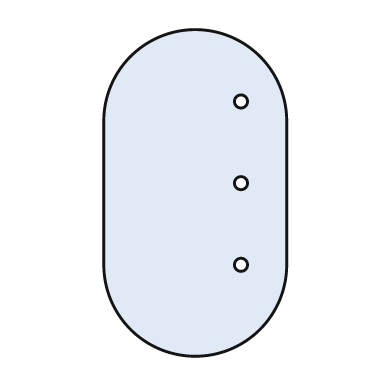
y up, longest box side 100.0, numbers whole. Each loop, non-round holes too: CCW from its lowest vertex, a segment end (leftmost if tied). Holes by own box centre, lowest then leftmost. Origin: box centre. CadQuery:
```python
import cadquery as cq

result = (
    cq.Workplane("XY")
    .moveTo(-28.0, -22.0)
    .threePointArc((0.0, -50.0), (28.0, -22.0))
    .lineTo(28.0, 22.0)
    .threePointArc((0.0, 50.0), (-28.0, 22.0))
    .close()
    .moveTo(14.0, -22.0)
    .circle(2.0)
    .moveTo(14.0, 3.0)
    .circle(2.0)
    .moveTo(14.0, 28.0)
    .circle(2.0)
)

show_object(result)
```